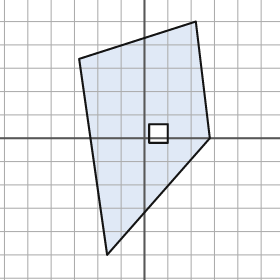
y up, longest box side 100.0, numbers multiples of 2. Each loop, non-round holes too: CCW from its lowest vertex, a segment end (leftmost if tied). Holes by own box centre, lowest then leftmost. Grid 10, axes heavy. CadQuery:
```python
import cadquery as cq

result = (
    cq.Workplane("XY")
    .moveTo(-16.0, -50.0)
    .lineTo(28.0, 0.0)
    .lineTo(22.0, 50.0)
    .lineTo(-28.0, 34.0)
    .close()
    .moveTo(2.0, -2.0)
    .lineTo(10.0, -2.0)
    .lineTo(10.0, 6.0)
    .lineTo(2.0, 6.0)
    .close()
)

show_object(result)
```